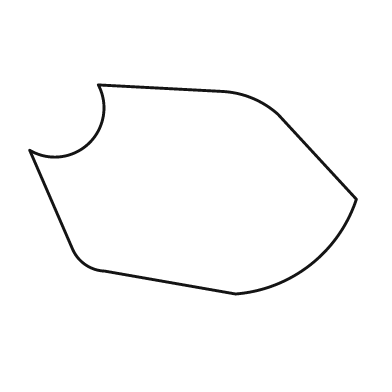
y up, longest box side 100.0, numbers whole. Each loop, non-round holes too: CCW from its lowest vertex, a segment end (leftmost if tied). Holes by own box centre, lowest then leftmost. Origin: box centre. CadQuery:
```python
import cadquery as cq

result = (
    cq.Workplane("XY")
    .moveTo(13.0, -32.0)
    .threePointArc((36.0, -23.0), (50.0, -3.0))
    .lineTo(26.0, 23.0)
    .threePointArc((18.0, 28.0), (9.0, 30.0))
    .lineTo(-29.0, 32.0)
    .threePointArc((-32.0, 14.0), (-50.0, 12.0))
    .lineTo(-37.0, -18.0)
    .threePointArc((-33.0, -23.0), (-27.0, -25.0))
    .close()
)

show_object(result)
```